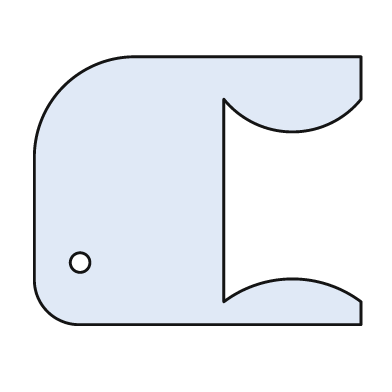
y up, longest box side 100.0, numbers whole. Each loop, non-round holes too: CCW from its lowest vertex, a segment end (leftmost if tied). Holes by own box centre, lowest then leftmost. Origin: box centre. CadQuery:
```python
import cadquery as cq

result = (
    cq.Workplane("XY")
    .moveTo(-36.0, -41.0)
    .lineTo(50.0, -41.0)
    .lineTo(50.0, -34.0)
    .threePointArc((29.0, -27.0), (8.0, -34.0))
    .lineTo(8.0, 28.0)
    .threePointArc((29.0, 18.0), (50.0, 28.0))
    .lineTo(50.0, 41.0)
    .lineTo(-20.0, 41.0)
    .threePointArc((-41.0, 32.0), (-50.0, 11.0))
    .lineTo(-50.0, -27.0)
    .threePointArc((-46.0, -37.0), (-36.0, -41.0))
    .close()
    .moveTo(-36.0, -22.0)
    .circle(3.0)
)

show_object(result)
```